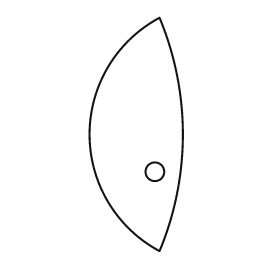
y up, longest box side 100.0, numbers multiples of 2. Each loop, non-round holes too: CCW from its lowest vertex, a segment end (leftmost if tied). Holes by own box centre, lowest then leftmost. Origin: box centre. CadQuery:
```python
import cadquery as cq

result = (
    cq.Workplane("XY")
    .moveTo(10.0, -50.0)
    .threePointArc((20.0, 0.0), (10.0, 50.0))
    .threePointArc((-20.0, 0.0), (10.0, -50.0))
    .close()
    .moveTo(8.0, -16.0)
    .circle(4.0)
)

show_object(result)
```